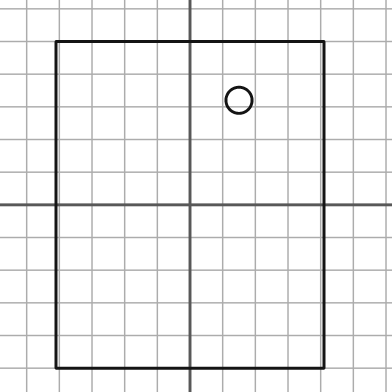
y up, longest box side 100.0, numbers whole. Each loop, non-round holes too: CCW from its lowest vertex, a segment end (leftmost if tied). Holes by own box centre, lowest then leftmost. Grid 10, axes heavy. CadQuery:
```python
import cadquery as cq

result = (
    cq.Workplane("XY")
    .moveTo(-41.0, -50.0)
    .lineTo(41.0, -50.0)
    .lineTo(41.0, 50.0)
    .lineTo(-41.0, 50.0)
    .close()
    .moveTo(15.0, 32.0)
    .circle(4.0)
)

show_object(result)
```